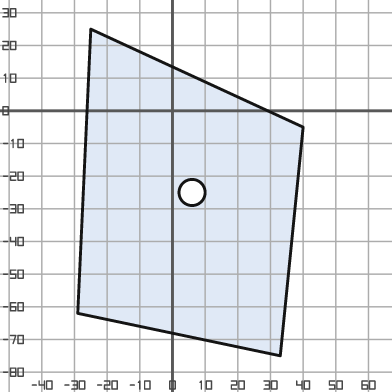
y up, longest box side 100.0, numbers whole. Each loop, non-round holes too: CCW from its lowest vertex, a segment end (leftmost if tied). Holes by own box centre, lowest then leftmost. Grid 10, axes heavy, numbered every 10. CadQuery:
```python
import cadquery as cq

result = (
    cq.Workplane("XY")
    .moveTo(33.0, -75.0)
    .lineTo(40.0, -5.0)
    .lineTo(-25.0, 25.0)
    .lineTo(-29.0, -62.0)
    .close()
    .moveTo(6.0, -25.0)
    .circle(4.0)
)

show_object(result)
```